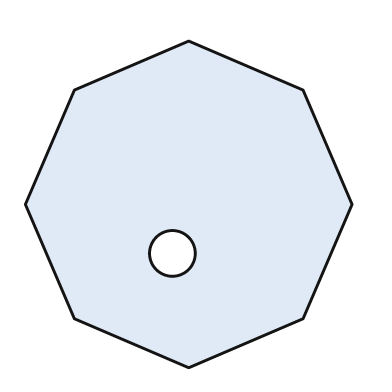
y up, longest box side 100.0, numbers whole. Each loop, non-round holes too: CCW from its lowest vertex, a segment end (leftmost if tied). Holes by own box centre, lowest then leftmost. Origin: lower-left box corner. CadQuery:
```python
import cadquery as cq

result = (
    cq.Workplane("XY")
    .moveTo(50.0, 0.0)
    .lineTo(85.0, 15.0)
    .lineTo(100.0, 50.0)
    .lineTo(85.0, 85.0)
    .lineTo(50.0, 100.0)
    .lineTo(15.0, 85.0)
    .lineTo(0.0, 50.0)
    .lineTo(15.0, 15.0)
    .close()
    .moveTo(45.0, 35.0)
    .circle(7.0)
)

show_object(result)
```